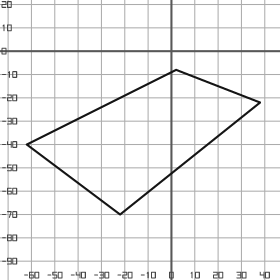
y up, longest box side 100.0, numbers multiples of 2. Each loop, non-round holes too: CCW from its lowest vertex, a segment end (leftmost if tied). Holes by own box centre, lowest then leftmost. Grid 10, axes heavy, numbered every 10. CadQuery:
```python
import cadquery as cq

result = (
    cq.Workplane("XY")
    .moveTo(-22.0, -70.0)
    .lineTo(38.0, -22.0)
    .lineTo(2.0, -8.0)
    .lineTo(-62.0, -40.0)
    .close()
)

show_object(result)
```